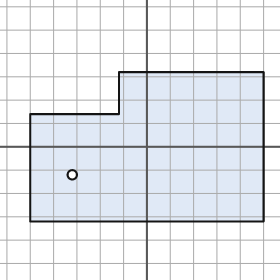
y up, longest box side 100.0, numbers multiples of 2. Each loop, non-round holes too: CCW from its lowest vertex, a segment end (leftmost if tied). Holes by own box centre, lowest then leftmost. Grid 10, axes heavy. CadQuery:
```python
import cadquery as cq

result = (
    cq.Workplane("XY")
    .moveTo(-50.0, -32.0)
    .lineTo(50.0, -32.0)
    .lineTo(50.0, 32.0)
    .lineTo(-12.0, 32.0)
    .lineTo(-12.0, 14.0)
    .lineTo(-50.0, 14.0)
    .close()
    .moveTo(-32.0, -12.0)
    .circle(2.0)
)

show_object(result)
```